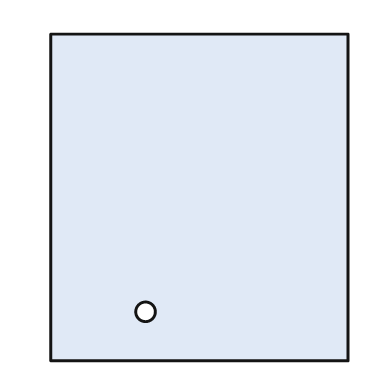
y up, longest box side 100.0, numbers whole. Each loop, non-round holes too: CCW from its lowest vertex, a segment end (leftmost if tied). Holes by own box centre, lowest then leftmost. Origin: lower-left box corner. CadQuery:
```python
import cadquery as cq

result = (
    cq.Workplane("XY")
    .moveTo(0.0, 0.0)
    .lineTo(91.0, 0.0)
    .lineTo(91.0, 100.0)
    .lineTo(0.0, 100.0)
    .close()
    .moveTo(29.0, 15.0)
    .circle(3.0)
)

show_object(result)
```